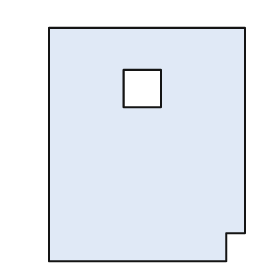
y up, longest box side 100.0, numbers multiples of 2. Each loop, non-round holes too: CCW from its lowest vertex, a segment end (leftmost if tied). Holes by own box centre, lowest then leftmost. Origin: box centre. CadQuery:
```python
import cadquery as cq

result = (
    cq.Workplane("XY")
    .moveTo(-42.0, -50.0)
    .lineTo(34.0, -50.0)
    .lineTo(34.0, -38.0)
    .lineTo(42.0, -38.0)
    .lineTo(42.0, 50.0)
    .lineTo(-42.0, 50.0)
    .close()
    .moveTo(-10.0, 16.0)
    .lineTo(6.0, 16.0)
    .lineTo(6.0, 32.0)
    .lineTo(-10.0, 32.0)
    .close()
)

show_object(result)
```